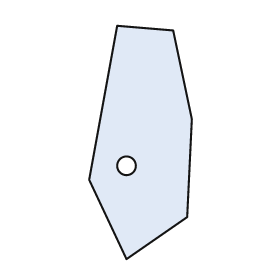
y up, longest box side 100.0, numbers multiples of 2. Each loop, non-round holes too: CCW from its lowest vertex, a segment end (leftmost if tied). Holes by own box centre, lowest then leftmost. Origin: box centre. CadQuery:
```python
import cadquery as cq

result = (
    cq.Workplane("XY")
    .moveTo(-6.0, -50.0)
    .lineTo(20.0, -32.0)
    .lineTo(22.0, 10.0)
    .lineTo(14.0, 48.0)
    .lineTo(-10.0, 50.0)
    .lineTo(-22.0, -16.0)
    .close()
    .moveTo(-6.0, -10.0)
    .circle(4.0)
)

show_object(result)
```